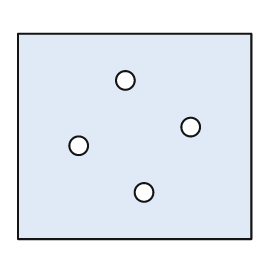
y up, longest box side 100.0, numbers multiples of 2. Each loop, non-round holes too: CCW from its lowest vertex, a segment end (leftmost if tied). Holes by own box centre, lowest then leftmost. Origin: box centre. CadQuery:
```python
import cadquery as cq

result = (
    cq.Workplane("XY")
    .moveTo(-50.0, -44.0)
    .lineTo(50.0, -44.0)
    .lineTo(50.0, 44.0)
    .lineTo(-50.0, 44.0)
    .close()
    .moveTo(4.0, -24.0)
    .circle(4.0)
    .moveTo(-24.0, -4.0)
    .circle(4.0)
    .moveTo(24.0, 4.0)
    .circle(4.0)
    .moveTo(-4.0, 24.0)
    .circle(4.0)
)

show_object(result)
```